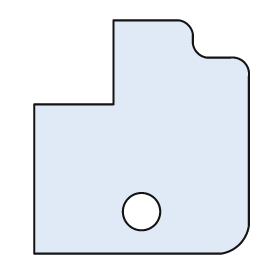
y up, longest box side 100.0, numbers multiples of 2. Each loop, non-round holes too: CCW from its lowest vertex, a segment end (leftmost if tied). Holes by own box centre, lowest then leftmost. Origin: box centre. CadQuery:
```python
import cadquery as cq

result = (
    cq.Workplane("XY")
    .moveTo(-46.0, -50.0)
    .lineTo(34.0, -50.0)
    .threePointArc((42.0, -46.0), (46.0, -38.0))
    .lineTo(46.0, 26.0)
    .threePointArc((44.0, 32.0), (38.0, 34.0))
    .lineTo(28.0, 34.0)
    .threePointArc((24.0, 36.0), (22.0, 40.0))
    .lineTo(22.0, 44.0)
    .threePointArc((20.0, 48.0), (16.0, 50.0))
    .lineTo(-12.0, 50.0)
    .lineTo(-12.0, 14.0)
    .lineTo(-46.0, 14.0)
    .close()
    .moveTo(0.0, -32.0)
    .circle(8.0)
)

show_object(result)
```